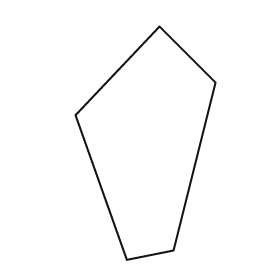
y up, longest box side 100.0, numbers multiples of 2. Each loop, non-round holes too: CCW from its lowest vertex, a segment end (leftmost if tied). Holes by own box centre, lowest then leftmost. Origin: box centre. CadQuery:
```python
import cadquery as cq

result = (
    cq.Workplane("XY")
    .moveTo(-8.0, -50.0)
    .lineTo(12.0, -46.0)
    .lineTo(30.0, 26.0)
    .lineTo(6.0, 50.0)
    .lineTo(-30.0, 12.0)
    .close()
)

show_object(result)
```